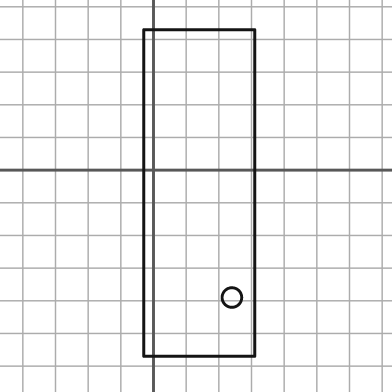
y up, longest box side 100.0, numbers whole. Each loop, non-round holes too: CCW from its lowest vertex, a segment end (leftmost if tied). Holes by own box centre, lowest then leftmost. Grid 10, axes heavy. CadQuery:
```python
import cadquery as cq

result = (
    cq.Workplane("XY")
    .moveTo(-3.0, -57.0)
    .lineTo(31.0, -57.0)
    .lineTo(31.0, 43.0)
    .lineTo(-3.0, 43.0)
    .close()
    .moveTo(24.0, -39.0)
    .circle(3.0)
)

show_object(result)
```